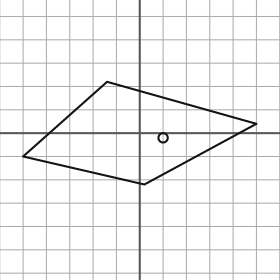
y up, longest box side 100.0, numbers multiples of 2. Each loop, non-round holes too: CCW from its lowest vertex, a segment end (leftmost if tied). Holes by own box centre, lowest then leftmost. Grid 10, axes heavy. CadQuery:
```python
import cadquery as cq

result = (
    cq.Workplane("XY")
    .moveTo(2.0, -22.0)
    .lineTo(50.0, 4.0)
    .lineTo(-14.0, 22.0)
    .lineTo(-50.0, -10.0)
    .close()
    .moveTo(10.0, -2.0)
    .circle(2.0)
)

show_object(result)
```